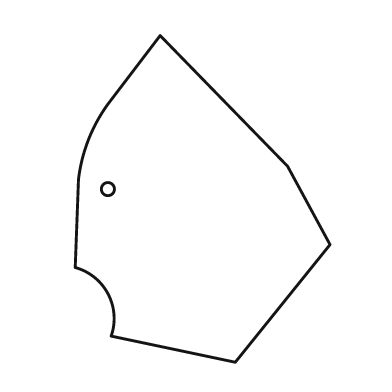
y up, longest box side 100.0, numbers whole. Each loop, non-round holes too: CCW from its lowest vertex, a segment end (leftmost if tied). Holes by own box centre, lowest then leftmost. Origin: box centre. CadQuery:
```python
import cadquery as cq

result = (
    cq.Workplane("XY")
    .moveTo(10.0, -50.0)
    .lineTo(39.0, -14.0)
    .lineTo(26.0, 10.0)
    .lineTo(-13.0, 50.0)
    .lineTo(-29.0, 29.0)
    .threePointArc((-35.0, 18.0), (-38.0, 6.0))
    .lineTo(-39.0, -21.0)
    .threePointArc((-29.0, -29.0), (-28.0, -42.0))
    .close()
    .moveTo(-29.0, 3.0)
    .circle(2.0)
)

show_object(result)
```